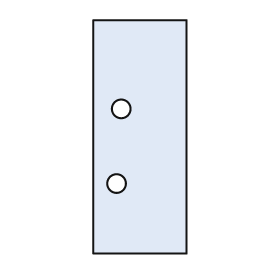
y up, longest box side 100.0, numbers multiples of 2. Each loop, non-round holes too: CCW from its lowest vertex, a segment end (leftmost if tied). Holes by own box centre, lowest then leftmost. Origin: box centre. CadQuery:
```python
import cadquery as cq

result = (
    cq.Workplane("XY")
    .moveTo(-20.0, -50.0)
    .lineTo(20.0, -50.0)
    .lineTo(20.0, 50.0)
    .lineTo(-20.0, 50.0)
    .close()
    .moveTo(-10.0, -20.0)
    .circle(4.0)
    .moveTo(-8.0, 12.0)
    .circle(4.0)
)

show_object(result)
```